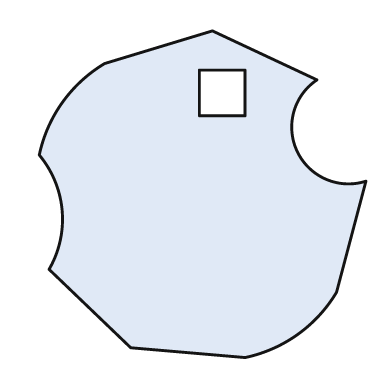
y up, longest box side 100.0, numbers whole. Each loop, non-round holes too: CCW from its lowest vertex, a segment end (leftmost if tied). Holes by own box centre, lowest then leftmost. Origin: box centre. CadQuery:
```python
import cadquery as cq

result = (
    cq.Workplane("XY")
    .moveTo(13.0, -50.0)
    .threePointArc((29.0, -43.0), (41.0, -30.0))
    .lineTo(50.0, 4.0)
    .threePointArc((29.0, 13.0), (35.0, 35.0))
    .lineTo(3.0, 50.0)
    .lineTo(-30.0, 40.0)
    .threePointArc((-43.0, 28.0), (-50.0, 12.0))
    .threePointArc((-43.0, -5.0), (-47.0, -23.0))
    .lineTo(-22.0, -47.0)
    .close()
    .moveTo(-1.0, 24.0)
    .lineTo(13.0, 24.0)
    .lineTo(13.0, 38.0)
    .lineTo(-1.0, 38.0)
    .close()
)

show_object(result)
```